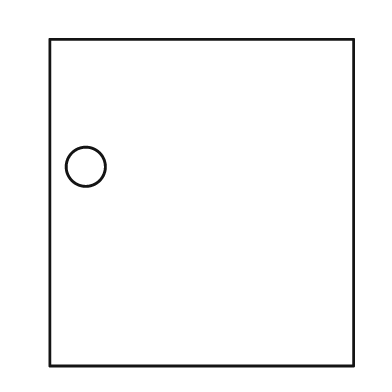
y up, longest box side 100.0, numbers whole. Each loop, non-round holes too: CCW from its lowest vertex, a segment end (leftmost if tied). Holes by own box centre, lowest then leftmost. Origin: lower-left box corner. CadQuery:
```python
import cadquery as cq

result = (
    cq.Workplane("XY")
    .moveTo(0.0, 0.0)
    .lineTo(93.0, 0.0)
    .lineTo(93.0, 100.0)
    .lineTo(0.0, 100.0)
    .close()
    .moveTo(11.0, 61.0)
    .circle(6.0)
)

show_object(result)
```